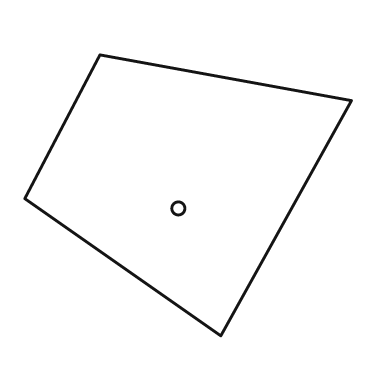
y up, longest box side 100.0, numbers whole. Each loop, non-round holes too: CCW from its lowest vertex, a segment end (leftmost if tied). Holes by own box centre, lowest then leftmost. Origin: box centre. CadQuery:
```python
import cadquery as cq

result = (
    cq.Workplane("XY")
    .moveTo(10.0, -43.0)
    .lineTo(50.0, 29.0)
    .lineTo(-27.0, 43.0)
    .lineTo(-50.0, -1.0)
    .close()
    .moveTo(-3.0, -4.0)
    .circle(2.0)
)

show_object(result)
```